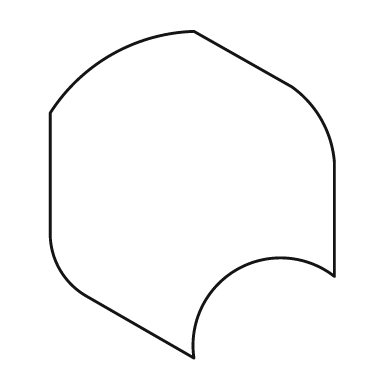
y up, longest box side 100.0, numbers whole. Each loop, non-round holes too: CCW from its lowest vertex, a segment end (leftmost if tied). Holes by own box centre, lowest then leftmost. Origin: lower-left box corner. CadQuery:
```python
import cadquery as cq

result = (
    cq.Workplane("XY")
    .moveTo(44.0, 0.0)
    .threePointArc((57.0, 27.0), (87.0, 25.0))
    .lineTo(87.0, 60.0)
    .threePointArc((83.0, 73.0), (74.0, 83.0))
    .lineTo(44.0, 100.0)
    .threePointArc((19.0, 93.0), (0.0, 75.0))
    .lineTo(0.0, 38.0)
    .threePointArc((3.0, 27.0), (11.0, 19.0))
    .close()
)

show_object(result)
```